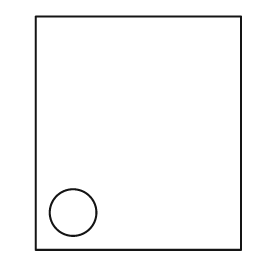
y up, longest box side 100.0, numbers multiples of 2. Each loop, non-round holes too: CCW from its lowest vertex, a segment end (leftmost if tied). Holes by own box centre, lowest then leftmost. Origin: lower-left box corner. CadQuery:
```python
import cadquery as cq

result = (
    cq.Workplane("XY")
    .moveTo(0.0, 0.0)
    .lineTo(88.0, 0.0)
    .lineTo(88.0, 100.0)
    .lineTo(0.0, 100.0)
    .close()
    .moveTo(16.0, 16.0)
    .circle(10.0)
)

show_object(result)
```